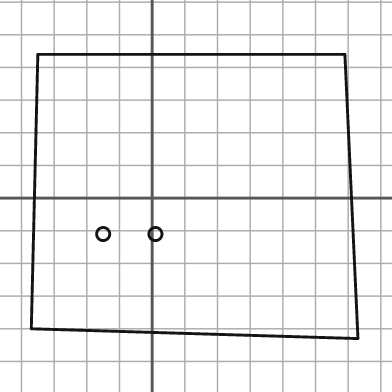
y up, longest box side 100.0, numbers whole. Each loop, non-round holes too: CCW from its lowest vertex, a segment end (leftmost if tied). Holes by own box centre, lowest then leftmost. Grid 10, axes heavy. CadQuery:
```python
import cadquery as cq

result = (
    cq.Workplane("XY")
    .moveTo(63.0, -43.0)
    .lineTo(59.0, 44.0)
    .lineTo(-35.0, 44.0)
    .lineTo(-37.0, -40.0)
    .close()
    .moveTo(-15.0, -11.0)
    .circle(2.0)
    .moveTo(1.0, -11.0)
    .circle(2.0)
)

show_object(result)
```